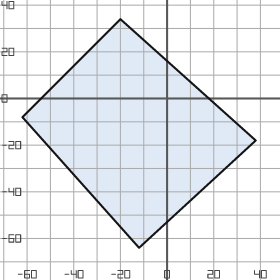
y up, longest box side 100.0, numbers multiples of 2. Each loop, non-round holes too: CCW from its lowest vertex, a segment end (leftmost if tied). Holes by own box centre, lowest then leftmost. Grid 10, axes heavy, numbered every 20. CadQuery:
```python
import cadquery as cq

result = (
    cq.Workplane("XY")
    .moveTo(-12.0, -64.0)
    .lineTo(38.0, -18.0)
    .lineTo(-20.0, 34.0)
    .lineTo(-62.0, -8.0)
    .close()
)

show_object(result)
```